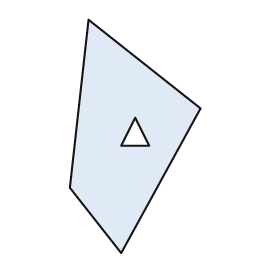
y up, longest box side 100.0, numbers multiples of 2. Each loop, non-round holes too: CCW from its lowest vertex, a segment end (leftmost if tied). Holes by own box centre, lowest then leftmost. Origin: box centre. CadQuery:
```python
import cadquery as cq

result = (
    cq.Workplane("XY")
    .moveTo(-6.0, -50.0)
    .lineTo(28.0, 12.0)
    .lineTo(-20.0, 50.0)
    .lineTo(-28.0, -22.0)
    .close()
    .moveTo(-6.0, -4.0)
    .lineTo(6.0, -4.0)
    .lineTo(0.0, 8.0)
    .close()
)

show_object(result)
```